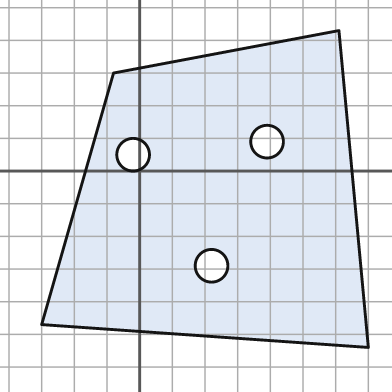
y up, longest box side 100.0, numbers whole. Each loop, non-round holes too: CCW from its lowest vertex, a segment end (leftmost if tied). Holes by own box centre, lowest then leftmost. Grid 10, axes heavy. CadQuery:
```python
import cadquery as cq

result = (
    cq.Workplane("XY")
    .moveTo(70.0, -54.0)
    .lineTo(61.0, 43.0)
    .lineTo(-8.0, 30.0)
    .lineTo(-30.0, -47.0)
    .close()
    .moveTo(22.0, -29.0)
    .circle(5.0)
    .moveTo(-2.0, 5.0)
    .circle(5.0)
    .moveTo(39.0, 9.0)
    .circle(5.0)
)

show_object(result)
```